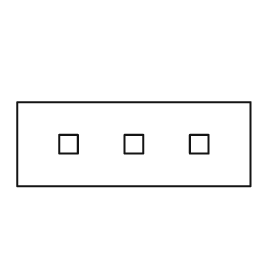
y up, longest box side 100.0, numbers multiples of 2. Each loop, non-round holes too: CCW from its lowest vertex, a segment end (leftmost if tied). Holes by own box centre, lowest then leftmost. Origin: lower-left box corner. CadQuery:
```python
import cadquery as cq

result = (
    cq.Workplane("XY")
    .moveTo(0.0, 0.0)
    .lineTo(100.0, 0.0)
    .lineTo(100.0, 36.0)
    .lineTo(0.0, 36.0)
    .close()
    .moveTo(18.0, 14.0)
    .lineTo(26.0, 14.0)
    .lineTo(26.0, 22.0)
    .lineTo(18.0, 22.0)
    .close()
    .moveTo(46.0, 14.0)
    .lineTo(54.0, 14.0)
    .lineTo(54.0, 22.0)
    .lineTo(46.0, 22.0)
    .close()
    .moveTo(74.0, 14.0)
    .lineTo(82.0, 14.0)
    .lineTo(82.0, 22.0)
    .lineTo(74.0, 22.0)
    .close()
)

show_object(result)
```